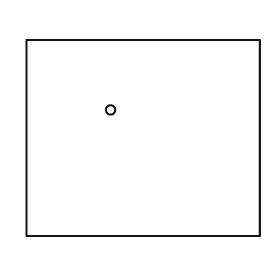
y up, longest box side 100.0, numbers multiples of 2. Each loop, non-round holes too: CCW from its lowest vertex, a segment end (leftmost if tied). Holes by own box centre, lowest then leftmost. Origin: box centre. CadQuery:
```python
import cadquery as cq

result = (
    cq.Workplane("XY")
    .moveTo(-50.0, -42.0)
    .lineTo(50.0, -42.0)
    .lineTo(50.0, 42.0)
    .lineTo(-50.0, 42.0)
    .close()
    .moveTo(-14.0, 12.0)
    .circle(2.0)
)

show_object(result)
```